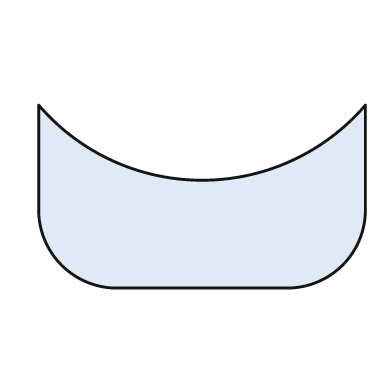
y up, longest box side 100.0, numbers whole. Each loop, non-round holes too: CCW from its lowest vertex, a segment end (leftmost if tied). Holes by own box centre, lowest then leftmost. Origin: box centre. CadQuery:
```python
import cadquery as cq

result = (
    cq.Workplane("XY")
    .moveTo(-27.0, -28.0)
    .lineTo(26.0, -28.0)
    .threePointArc((43.0, -21.0), (50.0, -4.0))
    .lineTo(50.0, 28.0)
    .threePointArc((0.0, 5.0), (-50.0, 28.0))
    .lineTo(-50.0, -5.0)
    .threePointArc((-43.0, -21.0), (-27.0, -28.0))
    .close()
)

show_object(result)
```